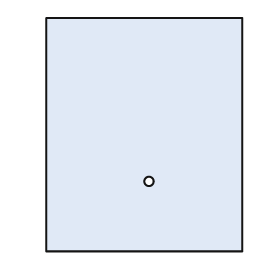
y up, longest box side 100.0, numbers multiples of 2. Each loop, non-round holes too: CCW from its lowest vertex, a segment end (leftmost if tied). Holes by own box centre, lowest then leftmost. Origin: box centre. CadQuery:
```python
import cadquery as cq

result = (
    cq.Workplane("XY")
    .moveTo(-42.0, -50.0)
    .lineTo(42.0, -50.0)
    .lineTo(42.0, 50.0)
    .lineTo(-42.0, 50.0)
    .close()
    .moveTo(2.0, -20.0)
    .circle(2.0)
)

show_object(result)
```